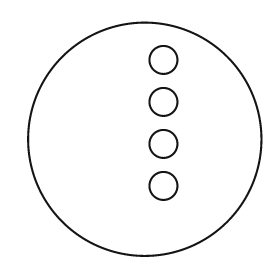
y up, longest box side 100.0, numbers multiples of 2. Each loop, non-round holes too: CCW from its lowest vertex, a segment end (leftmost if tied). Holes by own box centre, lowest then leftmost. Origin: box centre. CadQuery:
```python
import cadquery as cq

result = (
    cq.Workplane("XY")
    .moveTo(0.0, 0.0)
    .circle(50.0)
    .moveTo(8.0, -20.0)
    .circle(6.0)
    .moveTo(8.0, -2.0)
    .circle(6.0)
    .moveTo(8.0, 16.0)
    .circle(6.0)
    .moveTo(8.0, 34.0)
    .circle(6.0)
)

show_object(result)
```